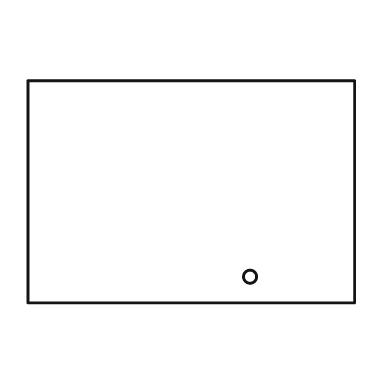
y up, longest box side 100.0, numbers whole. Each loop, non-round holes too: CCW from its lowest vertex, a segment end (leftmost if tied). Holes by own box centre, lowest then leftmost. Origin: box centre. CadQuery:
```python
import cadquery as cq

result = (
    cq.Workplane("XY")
    .moveTo(-50.0, -34.0)
    .lineTo(50.0, -34.0)
    .lineTo(50.0, 34.0)
    .lineTo(-50.0, 34.0)
    .close()
    .moveTo(18.0, -26.0)
    .circle(2.0)
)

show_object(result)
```